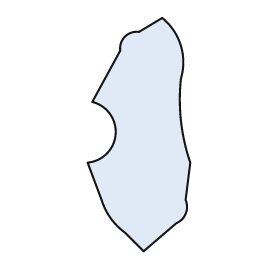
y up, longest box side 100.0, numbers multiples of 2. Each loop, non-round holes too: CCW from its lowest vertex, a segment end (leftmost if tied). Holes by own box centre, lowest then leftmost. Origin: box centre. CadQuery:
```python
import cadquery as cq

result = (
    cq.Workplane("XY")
    .moveTo(2.0, -50.0)
    .lineTo(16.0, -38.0)
    .threePointArc((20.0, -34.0), (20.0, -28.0))
    .lineTo(22.0, -12.0)
    .threePointArc((18.0, 6.0), (18.0, 24.0))
    .threePointArc((18.0, 38.0), (10.0, 50.0))
    .lineTo(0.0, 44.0)
    .threePointArc((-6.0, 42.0), (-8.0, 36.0))
    .lineTo(-20.0, 14.0)
    .threePointArc((-10.0, 0.0), (-22.0, -12.0))
    .lineTo(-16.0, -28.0)
    .threePointArc((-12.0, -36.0), (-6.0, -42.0))
    .close()
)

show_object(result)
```